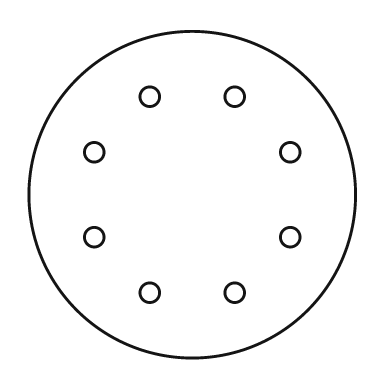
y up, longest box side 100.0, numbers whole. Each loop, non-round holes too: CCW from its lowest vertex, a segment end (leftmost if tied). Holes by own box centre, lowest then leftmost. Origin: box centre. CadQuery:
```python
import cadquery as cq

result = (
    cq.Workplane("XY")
    .moveTo(0.0, 0.0)
    .circle(50.0)
    .moveTo(-13.0, -30.0)
    .circle(3.0)
    .moveTo(13.0, -30.0)
    .circle(3.0)
    .moveTo(-30.0, -13.0)
    .circle(3.0)
    .moveTo(30.0, -13.0)
    .circle(3.0)
    .moveTo(-30.0, 13.0)
    .circle(3.0)
    .moveTo(30.0, 13.0)
    .circle(3.0)
    .moveTo(-13.0, 30.0)
    .circle(3.0)
    .moveTo(13.0, 30.0)
    .circle(3.0)
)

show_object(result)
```